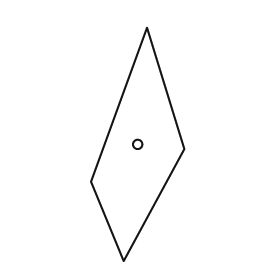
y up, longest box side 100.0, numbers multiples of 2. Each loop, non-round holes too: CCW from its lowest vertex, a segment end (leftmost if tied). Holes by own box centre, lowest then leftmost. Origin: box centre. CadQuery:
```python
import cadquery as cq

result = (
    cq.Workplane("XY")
    .moveTo(-6.0, -50.0)
    .lineTo(20.0, -2.0)
    .lineTo(4.0, 50.0)
    .lineTo(-20.0, -16.0)
    .close()
    .moveTo(0.0, 0.0)
    .circle(2.0)
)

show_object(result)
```